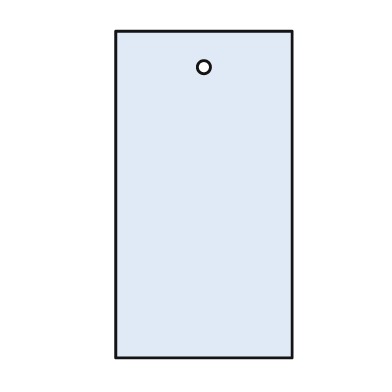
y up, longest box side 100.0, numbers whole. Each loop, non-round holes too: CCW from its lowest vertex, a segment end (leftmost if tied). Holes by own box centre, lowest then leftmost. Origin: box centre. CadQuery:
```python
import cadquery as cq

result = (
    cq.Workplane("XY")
    .moveTo(-27.0, -50.0)
    .lineTo(27.0, -50.0)
    .lineTo(27.0, 50.0)
    .lineTo(-27.0, 50.0)
    .close()
    .moveTo(0.0, 39.0)
    .circle(2.0)
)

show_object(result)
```